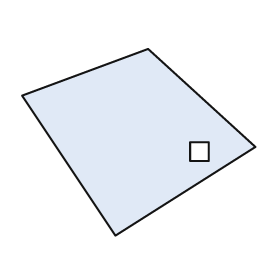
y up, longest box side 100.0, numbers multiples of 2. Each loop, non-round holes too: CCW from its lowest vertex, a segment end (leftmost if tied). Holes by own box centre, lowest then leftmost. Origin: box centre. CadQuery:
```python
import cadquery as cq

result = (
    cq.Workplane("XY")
    .moveTo(-10.0, -40.0)
    .lineTo(50.0, -2.0)
    .lineTo(4.0, 40.0)
    .lineTo(-50.0, 20.0)
    .close()
    .moveTo(22.0, -8.0)
    .lineTo(30.0, -8.0)
    .lineTo(30.0, 0.0)
    .lineTo(22.0, 0.0)
    .close()
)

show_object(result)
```